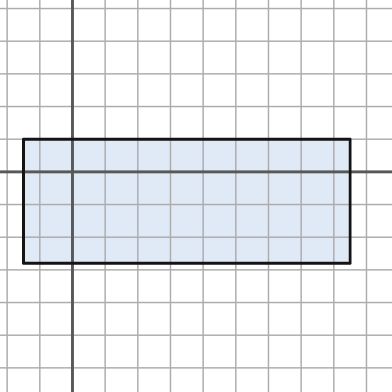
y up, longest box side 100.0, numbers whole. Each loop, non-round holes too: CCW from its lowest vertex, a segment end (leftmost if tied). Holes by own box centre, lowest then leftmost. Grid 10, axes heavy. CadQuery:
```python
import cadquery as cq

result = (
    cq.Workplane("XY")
    .moveTo(-15.0, -28.0)
    .lineTo(85.0, -28.0)
    .lineTo(85.0, 10.0)
    .lineTo(-15.0, 10.0)
    .close()
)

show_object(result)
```